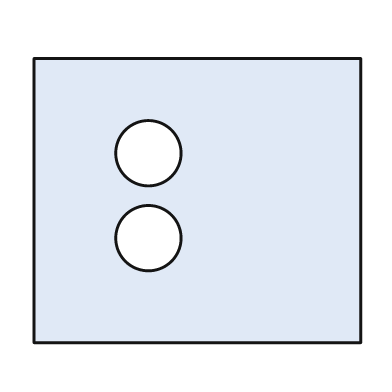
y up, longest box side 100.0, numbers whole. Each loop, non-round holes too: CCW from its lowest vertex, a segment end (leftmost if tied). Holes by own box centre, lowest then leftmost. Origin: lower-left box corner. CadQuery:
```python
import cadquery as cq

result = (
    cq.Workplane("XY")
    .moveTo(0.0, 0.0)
    .lineTo(100.0, 0.0)
    .lineTo(100.0, 87.0)
    .lineTo(0.0, 87.0)
    .close()
    .moveTo(35.0, 32.0)
    .circle(10.0)
    .moveTo(35.0, 58.0)
    .circle(10.0)
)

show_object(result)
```